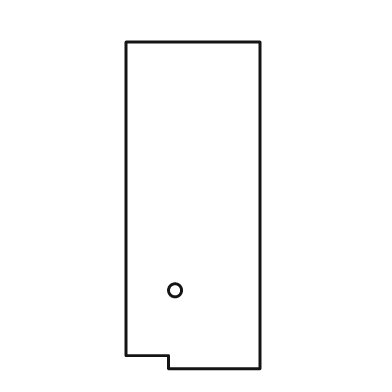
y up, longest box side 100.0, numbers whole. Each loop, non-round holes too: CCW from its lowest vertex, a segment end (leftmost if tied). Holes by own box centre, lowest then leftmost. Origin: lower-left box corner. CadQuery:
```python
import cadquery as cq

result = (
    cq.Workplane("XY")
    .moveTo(13.0, 0.0)
    .lineTo(41.0, 0.0)
    .lineTo(41.0, 100.0)
    .lineTo(0.0, 100.0)
    .lineTo(0.0, 4.0)
    .lineTo(13.0, 4.0)
    .close()
    .moveTo(15.0, 24.0)
    .circle(2.0)
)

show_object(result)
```